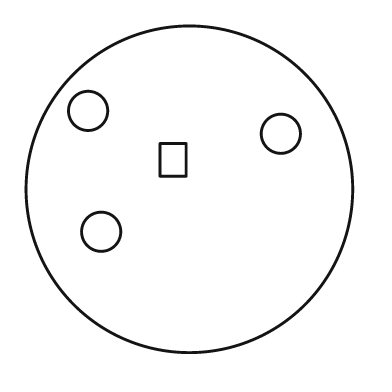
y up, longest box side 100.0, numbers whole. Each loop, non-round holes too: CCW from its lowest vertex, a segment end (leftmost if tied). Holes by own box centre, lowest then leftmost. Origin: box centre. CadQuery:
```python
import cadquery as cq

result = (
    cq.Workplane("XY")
    .moveTo(0.0, 0.0)
    .circle(50.0)
    .moveTo(-27.0, -13.0)
    .circle(6.0)
    .moveTo(-9.0, 4.0)
    .lineTo(-1.0, 4.0)
    .lineTo(-1.0, 14.0)
    .lineTo(-9.0, 14.0)
    .close()
    .moveTo(28.0, 17.0)
    .circle(6.0)
    .moveTo(-31.0, 24.0)
    .circle(6.0)
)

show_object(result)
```